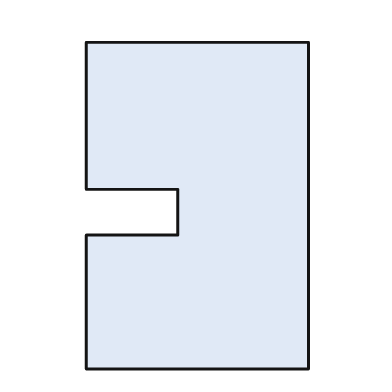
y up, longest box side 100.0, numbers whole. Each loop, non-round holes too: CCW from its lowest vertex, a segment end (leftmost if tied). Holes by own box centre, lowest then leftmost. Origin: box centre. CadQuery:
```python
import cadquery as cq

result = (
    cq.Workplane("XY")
    .moveTo(-34.0, -50.0)
    .lineTo(34.0, -50.0)
    .lineTo(34.0, 50.0)
    .lineTo(-34.0, 50.0)
    .lineTo(-34.0, 5.0)
    .lineTo(-6.0, 5.0)
    .lineTo(-6.0, -9.0)
    .lineTo(-34.0, -9.0)
    .close()
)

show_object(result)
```